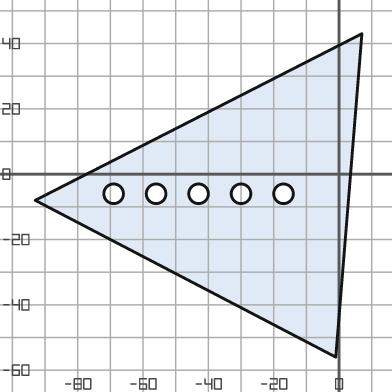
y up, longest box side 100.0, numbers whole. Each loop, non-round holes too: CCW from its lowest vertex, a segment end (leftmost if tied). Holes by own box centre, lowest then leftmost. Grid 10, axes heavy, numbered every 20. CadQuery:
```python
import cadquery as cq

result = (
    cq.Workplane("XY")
    .moveTo(-1.0, -56.0)
    .lineTo(7.0, 43.0)
    .lineTo(-93.0, -8.0)
    .close()
    .moveTo(-69.0, -6.0)
    .circle(3.0)
    .moveTo(-56.0, -6.0)
    .circle(3.0)
    .moveTo(-43.0, -6.0)
    .circle(3.0)
    .moveTo(-30.0, -6.0)
    .circle(3.0)
    .moveTo(-17.0, -6.0)
    .circle(3.0)
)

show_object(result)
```